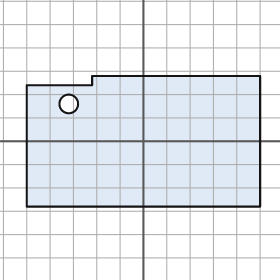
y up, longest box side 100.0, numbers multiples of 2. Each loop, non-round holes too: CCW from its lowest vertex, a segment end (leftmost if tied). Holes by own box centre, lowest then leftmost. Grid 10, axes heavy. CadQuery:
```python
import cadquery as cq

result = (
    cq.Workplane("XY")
    .moveTo(-50.0, -28.0)
    .lineTo(50.0, -28.0)
    .lineTo(50.0, 28.0)
    .lineTo(-22.0, 28.0)
    .lineTo(-22.0, 24.0)
    .lineTo(-50.0, 24.0)
    .close()
    .moveTo(-32.0, 16.0)
    .circle(4.0)
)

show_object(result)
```